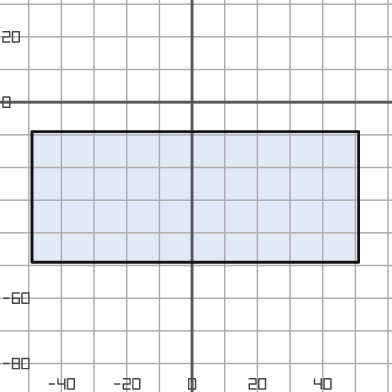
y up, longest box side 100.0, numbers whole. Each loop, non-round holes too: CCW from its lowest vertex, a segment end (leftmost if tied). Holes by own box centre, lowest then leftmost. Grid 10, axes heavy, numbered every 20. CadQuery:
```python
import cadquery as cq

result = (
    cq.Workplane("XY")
    .moveTo(-49.0, -49.0)
    .lineTo(51.0, -49.0)
    .lineTo(51.0, -9.0)
    .lineTo(-49.0, -9.0)
    .close()
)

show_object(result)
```